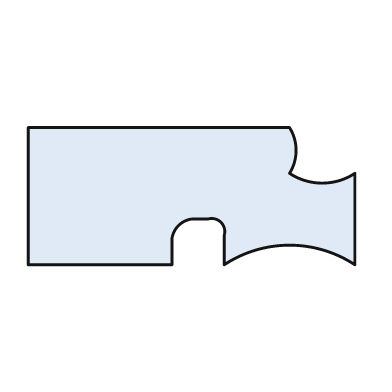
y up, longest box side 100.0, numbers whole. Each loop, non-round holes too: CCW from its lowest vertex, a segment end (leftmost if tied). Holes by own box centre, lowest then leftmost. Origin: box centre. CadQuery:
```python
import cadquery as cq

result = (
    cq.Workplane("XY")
    .moveTo(-50.0, -21.0)
    .lineTo(-6.0, -21.0)
    .lineTo(-6.0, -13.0)
    .threePointArc((-4.0, -9.0), (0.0, -7.0))
    .lineTo(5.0, -7.0)
    .threePointArc((9.0, -8.0), (10.0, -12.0))
    .lineTo(10.0, -21.0)
    .threePointArc((30.0, -15.0), (50.0, -21.0))
    .lineTo(50.0, 7.0)
    .threePointArc((40.0, 4.0), (30.0, 7.0))
    .threePointArc((32.0, 14.0), (30.0, 21.0))
    .lineTo(-50.0, 21.0)
    .close()
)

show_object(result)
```